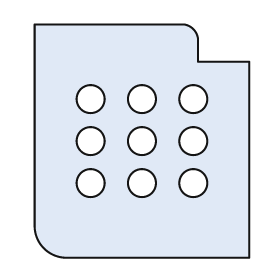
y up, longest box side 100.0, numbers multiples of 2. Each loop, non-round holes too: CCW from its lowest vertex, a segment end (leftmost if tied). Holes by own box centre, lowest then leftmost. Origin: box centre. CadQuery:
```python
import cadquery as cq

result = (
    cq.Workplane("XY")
    .moveTo(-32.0, -50.0)
    .lineTo(46.0, -50.0)
    .lineTo(46.0, 34.0)
    .lineTo(24.0, 34.0)
    .lineTo(24.0, 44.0)
    .threePointArc((22.0, 48.0), (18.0, 50.0))
    .lineTo(-46.0, 50.0)
    .lineTo(-46.0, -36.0)
    .threePointArc((-42.0, -46.0), (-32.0, -50.0))
    .close()
    .moveTo(-22.0, -18.0)
    .circle(6.0)
    .moveTo(0.0, -18.0)
    .circle(6.0)
    .moveTo(22.0, -18.0)
    .circle(6.0)
    .moveTo(-22.0, 0.0)
    .circle(6.0)
    .moveTo(0.0, 0.0)
    .circle(6.0)
    .moveTo(22.0, 0.0)
    .circle(6.0)
    .moveTo(-22.0, 18.0)
    .circle(6.0)
    .moveTo(0.0, 18.0)
    .circle(6.0)
    .moveTo(22.0, 18.0)
    .circle(6.0)
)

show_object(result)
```